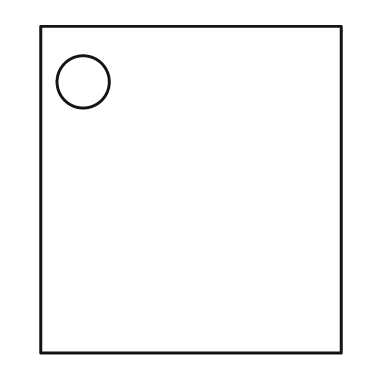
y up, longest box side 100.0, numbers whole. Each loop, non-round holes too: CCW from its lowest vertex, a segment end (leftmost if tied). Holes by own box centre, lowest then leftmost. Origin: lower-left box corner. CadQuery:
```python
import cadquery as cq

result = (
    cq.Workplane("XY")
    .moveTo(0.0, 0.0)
    .lineTo(92.0, 0.0)
    .lineTo(92.0, 100.0)
    .lineTo(0.0, 100.0)
    .close()
    .moveTo(13.0, 83.0)
    .circle(8.0)
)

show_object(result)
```